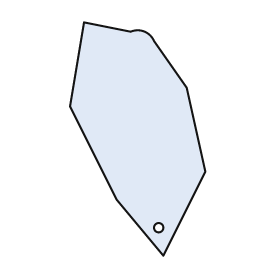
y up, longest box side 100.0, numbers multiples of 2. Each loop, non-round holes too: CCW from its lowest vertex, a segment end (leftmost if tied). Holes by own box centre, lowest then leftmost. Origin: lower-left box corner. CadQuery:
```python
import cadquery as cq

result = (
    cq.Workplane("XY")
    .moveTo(40.0, 0.0)
    .lineTo(58.0, 36.0)
    .lineTo(50.0, 72.0)
    .lineTo(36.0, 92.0)
    .threePointArc((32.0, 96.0), (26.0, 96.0))
    .lineTo(6.0, 100.0)
    .lineTo(0.0, 64.0)
    .lineTo(20.0, 24.0)
    .close()
    .moveTo(38.0, 12.0)
    .circle(2.0)
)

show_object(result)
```